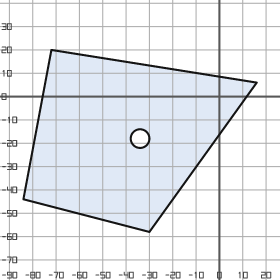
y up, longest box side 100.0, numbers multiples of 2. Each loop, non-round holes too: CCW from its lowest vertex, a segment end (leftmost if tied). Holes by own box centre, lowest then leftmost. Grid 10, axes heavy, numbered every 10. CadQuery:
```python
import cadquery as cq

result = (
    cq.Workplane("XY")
    .moveTo(-30.0, -58.0)
    .lineTo(16.0, 6.0)
    .lineTo(-72.0, 20.0)
    .lineTo(-84.0, -44.0)
    .close()
    .moveTo(-34.0, -18.0)
    .circle(4.0)
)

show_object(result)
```